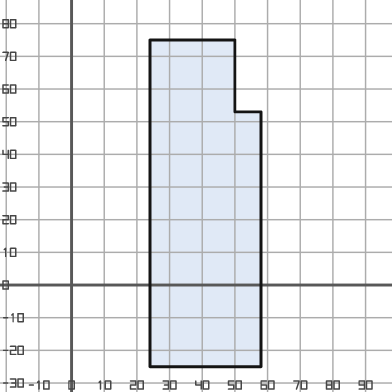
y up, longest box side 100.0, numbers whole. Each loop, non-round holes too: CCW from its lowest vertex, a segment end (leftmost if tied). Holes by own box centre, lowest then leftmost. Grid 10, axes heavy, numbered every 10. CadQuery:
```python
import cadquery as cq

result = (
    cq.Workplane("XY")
    .moveTo(24.0, -25.0)
    .lineTo(58.0, -25.0)
    .lineTo(58.0, 53.0)
    .lineTo(50.0, 53.0)
    .lineTo(50.0, 75.0)
    .lineTo(24.0, 75.0)
    .close()
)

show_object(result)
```